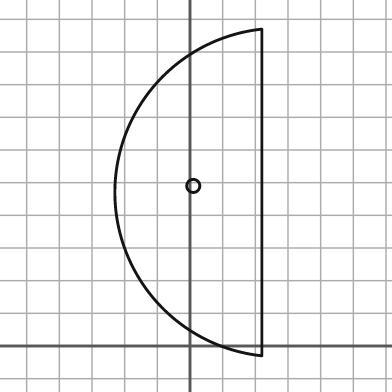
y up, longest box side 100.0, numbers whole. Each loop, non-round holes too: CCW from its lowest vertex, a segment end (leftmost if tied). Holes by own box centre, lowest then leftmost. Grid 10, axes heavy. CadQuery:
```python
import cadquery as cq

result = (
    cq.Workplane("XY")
    .moveTo(22.0, -3.0)
    .lineTo(22.0, 97.0)
    .threePointArc((-23.0, 47.0), (22.0, -3.0))
    .close()
    .moveTo(1.0, 49.0)
    .circle(2.0)
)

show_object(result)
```